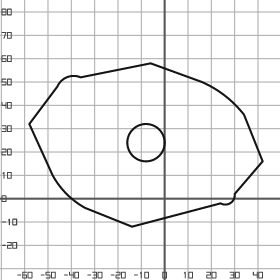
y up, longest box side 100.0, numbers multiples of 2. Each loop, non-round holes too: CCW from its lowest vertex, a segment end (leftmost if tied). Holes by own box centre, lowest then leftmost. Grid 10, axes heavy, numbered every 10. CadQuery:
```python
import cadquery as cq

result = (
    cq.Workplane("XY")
    .moveTo(-14.0, -12.0)
    .lineTo(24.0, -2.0)
    .threePointArc((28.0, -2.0), (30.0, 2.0))
    .lineTo(42.0, 16.0)
    .lineTo(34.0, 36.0)
    .threePointArc((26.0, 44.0), (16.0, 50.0))
    .lineTo(-6.0, 58.0)
    .lineTo(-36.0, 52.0)
    .threePointArc((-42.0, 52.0), (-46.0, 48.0))
    .lineTo(-58.0, 32.0)
    .lineTo(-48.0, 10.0)
    .threePointArc((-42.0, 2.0), (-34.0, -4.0))
    .close()
    .moveTo(-8.0, 24.0)
    .circle(8.0)
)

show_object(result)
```